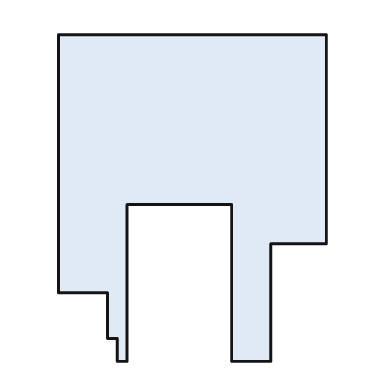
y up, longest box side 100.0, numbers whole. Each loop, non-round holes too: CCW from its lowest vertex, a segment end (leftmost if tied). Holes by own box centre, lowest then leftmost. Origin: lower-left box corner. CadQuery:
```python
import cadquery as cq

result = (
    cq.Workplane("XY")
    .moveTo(18.0, 0.0)
    .lineTo(21.0, 0.0)
    .lineTo(21.0, 48.0)
    .lineTo(53.0, 48.0)
    .lineTo(53.0, 0.0)
    .lineTo(65.0, 0.0)
    .lineTo(65.0, 36.0)
    .lineTo(82.0, 36.0)
    .lineTo(82.0, 100.0)
    .lineTo(0.0, 100.0)
    .lineTo(0.0, 21.0)
    .lineTo(15.0, 21.0)
    .lineTo(15.0, 7.0)
    .lineTo(18.0, 7.0)
    .close()
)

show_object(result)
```